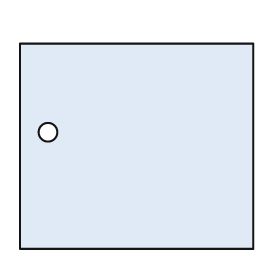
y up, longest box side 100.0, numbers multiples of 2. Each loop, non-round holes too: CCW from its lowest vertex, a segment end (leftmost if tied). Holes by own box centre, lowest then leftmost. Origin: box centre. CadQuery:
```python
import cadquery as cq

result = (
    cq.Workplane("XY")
    .moveTo(-50.0, -44.0)
    .lineTo(50.0, -44.0)
    .lineTo(50.0, 44.0)
    .lineTo(-50.0, 44.0)
    .close()
    .moveTo(-38.0, 6.0)
    .circle(4.0)
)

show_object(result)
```